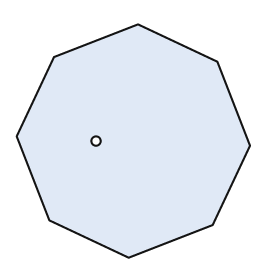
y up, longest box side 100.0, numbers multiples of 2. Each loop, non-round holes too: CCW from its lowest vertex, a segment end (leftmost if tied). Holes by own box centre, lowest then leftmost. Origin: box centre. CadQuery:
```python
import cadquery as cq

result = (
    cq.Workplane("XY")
    .moveTo(-2.0, -50.0)
    .lineTo(34.0, -36.0)
    .lineTo(50.0, -2.0)
    .lineTo(36.0, 34.0)
    .lineTo(2.0, 50.0)
    .lineTo(-34.0, 36.0)
    .lineTo(-50.0, 2.0)
    .lineTo(-36.0, -34.0)
    .close()
    .moveTo(-16.0, 0.0)
    .circle(2.0)
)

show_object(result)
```